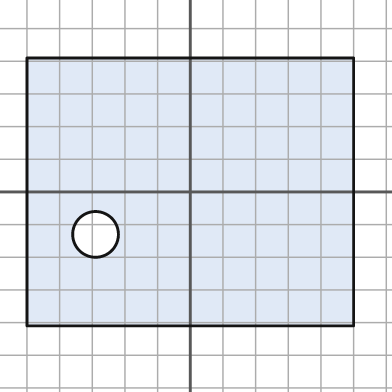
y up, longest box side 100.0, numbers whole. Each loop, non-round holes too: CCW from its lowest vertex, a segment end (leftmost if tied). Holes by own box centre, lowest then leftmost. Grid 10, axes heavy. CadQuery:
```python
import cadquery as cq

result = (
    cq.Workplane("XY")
    .moveTo(-50.0, -41.0)
    .lineTo(50.0, -41.0)
    .lineTo(50.0, 41.0)
    .lineTo(-50.0, 41.0)
    .close()
    .moveTo(-29.0, -13.0)
    .circle(7.0)
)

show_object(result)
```